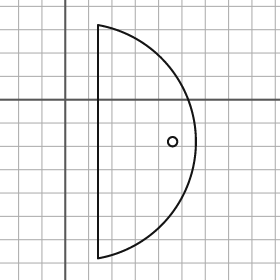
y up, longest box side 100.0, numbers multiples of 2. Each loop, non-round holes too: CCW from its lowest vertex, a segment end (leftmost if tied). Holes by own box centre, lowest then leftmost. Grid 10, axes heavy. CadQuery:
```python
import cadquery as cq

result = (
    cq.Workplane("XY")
    .moveTo(14.0, -68.0)
    .threePointArc((56.0, -18.0), (14.0, 32.0))
    .close()
    .moveTo(46.0, -18.0)
    .circle(2.0)
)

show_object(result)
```